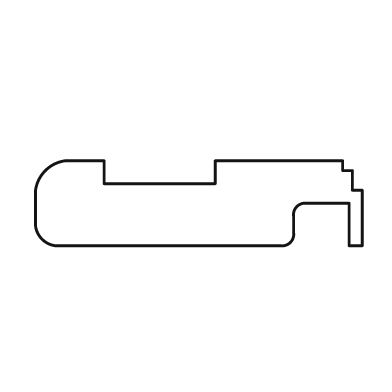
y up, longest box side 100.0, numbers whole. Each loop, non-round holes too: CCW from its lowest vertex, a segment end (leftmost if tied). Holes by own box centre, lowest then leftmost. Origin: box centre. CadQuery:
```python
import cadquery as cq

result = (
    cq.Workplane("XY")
    .moveTo(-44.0, -13.0)
    .lineTo(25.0, -13.0)
    .threePointArc((28.0, -12.0), (29.0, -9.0))
    .lineTo(29.0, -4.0)
    .threePointArc((30.0, -1.0), (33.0, 0.0))
    .lineTo(46.0, 0.0)
    .lineTo(46.0, -13.0)
    .lineTo(50.0, -13.0)
    .lineTo(50.0, 4.0)
    .lineTo(47.0, 4.0)
    .lineTo(47.0, 10.0)
    .lineTo(44.0, 10.0)
    .lineTo(44.0, 13.0)
    .lineTo(5.0, 13.0)
    .lineTo(5.0, 6.0)
    .lineTo(-29.0, 6.0)
    .lineTo(-29.0, 13.0)
    .lineTo(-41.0, 13.0)
    .threePointArc((-47.0, 10.0), (-50.0, 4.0))
    .lineTo(-50.0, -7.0)
    .threePointArc((-48.0, -11.0), (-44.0, -13.0))
    .close()
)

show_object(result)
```